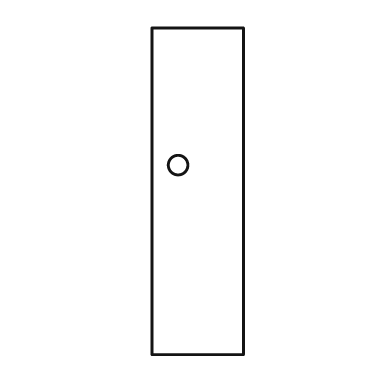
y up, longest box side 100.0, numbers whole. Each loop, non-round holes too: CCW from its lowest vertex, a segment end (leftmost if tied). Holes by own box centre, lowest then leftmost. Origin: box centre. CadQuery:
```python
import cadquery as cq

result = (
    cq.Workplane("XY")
    .moveTo(-14.0, -50.0)
    .lineTo(14.0, -50.0)
    .lineTo(14.0, 50.0)
    .lineTo(-14.0, 50.0)
    .close()
    .moveTo(-6.0, 8.0)
    .circle(3.0)
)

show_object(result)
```